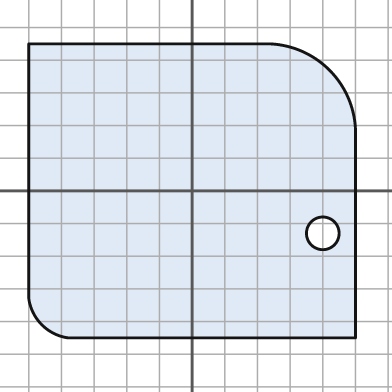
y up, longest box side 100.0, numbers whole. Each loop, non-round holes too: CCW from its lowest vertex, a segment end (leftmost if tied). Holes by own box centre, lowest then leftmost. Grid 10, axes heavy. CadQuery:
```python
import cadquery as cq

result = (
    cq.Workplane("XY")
    .moveTo(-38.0, -45.0)
    .lineTo(50.0, -45.0)
    .lineTo(50.0, 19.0)
    .threePointArc((42.0, 37.0), (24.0, 45.0))
    .lineTo(-50.0, 45.0)
    .lineTo(-50.0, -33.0)
    .threePointArc((-46.0, -41.0), (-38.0, -45.0))
    .close()
    .moveTo(40.0, -13.0)
    .circle(5.0)
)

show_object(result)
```